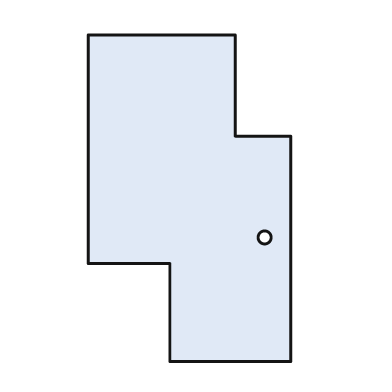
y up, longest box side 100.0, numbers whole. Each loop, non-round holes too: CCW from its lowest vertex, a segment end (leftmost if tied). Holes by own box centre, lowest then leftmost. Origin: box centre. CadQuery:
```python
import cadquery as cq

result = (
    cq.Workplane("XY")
    .moveTo(-6.0, -50.0)
    .lineTo(31.0, -50.0)
    .lineTo(31.0, 19.0)
    .lineTo(14.0, 19.0)
    .lineTo(14.0, 50.0)
    .lineTo(-31.0, 50.0)
    .lineTo(-31.0, -20.0)
    .lineTo(-6.0, -20.0)
    .close()
    .moveTo(23.0, -12.0)
    .circle(2.0)
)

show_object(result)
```